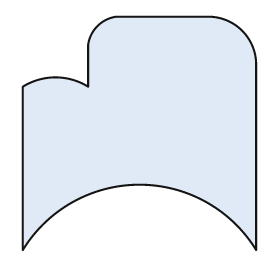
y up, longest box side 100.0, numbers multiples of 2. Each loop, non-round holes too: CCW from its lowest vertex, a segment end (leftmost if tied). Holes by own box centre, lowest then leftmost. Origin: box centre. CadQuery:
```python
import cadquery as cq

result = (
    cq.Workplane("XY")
    .moveTo(-50.0, -50.0)
    .threePointArc((0.0, -22.0), (50.0, -50.0))
    .lineTo(50.0, 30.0)
    .threePointArc((44.0, 44.0), (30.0, 50.0))
    .lineTo(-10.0, 50.0)
    .threePointArc((-18.0, 46.0), (-22.0, 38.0))
    .lineTo(-22.0, 20.0)
    .threePointArc((-36.0, 24.0), (-50.0, 20.0))
    .close()
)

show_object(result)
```